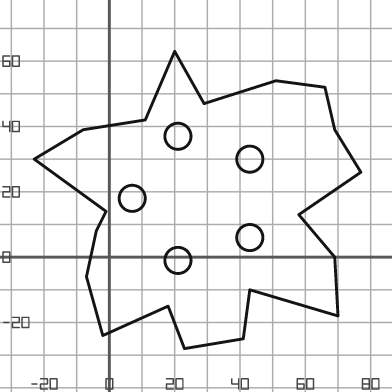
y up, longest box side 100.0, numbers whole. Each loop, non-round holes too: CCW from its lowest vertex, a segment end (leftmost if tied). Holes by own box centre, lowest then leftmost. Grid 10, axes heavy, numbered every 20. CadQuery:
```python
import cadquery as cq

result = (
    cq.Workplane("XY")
    .moveTo(23.0, -28.0)
    .lineTo(41.0, -25.0)
    .lineTo(43.0, -10.0)
    .lineTo(70.0, -18.0)
    .lineTo(69.0, 0.0)
    .lineTo(58.0, 13.0)
    .lineTo(77.0, 26.0)
    .lineTo(69.0, 39.0)
    .lineTo(66.0, 52.0)
    .lineTo(51.0, 54.0)
    .lineTo(29.0, 47.0)
    .lineTo(20.0, 63.0)
    .lineTo(11.0, 42.0)
    .lineTo(-8.0, 39.0)
    .lineTo(-23.0, 30.0)
    .lineTo(-1.0, 14.0)
    .lineTo(-4.0, 8.0)
    .lineTo(-7.0, -6.0)
    .lineTo(-2.0, -24.0)
    .lineTo(18.0, -15.0)
    .close()
    .moveTo(21.0, -1.0)
    .circle(4.0)
    .moveTo(43.0, 6.0)
    .circle(4.0)
    .moveTo(7.0, 18.0)
    .circle(4.0)
    .moveTo(43.0, 30.0)
    .circle(4.0)
    .moveTo(21.0, 37.0)
    .circle(4.0)
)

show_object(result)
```